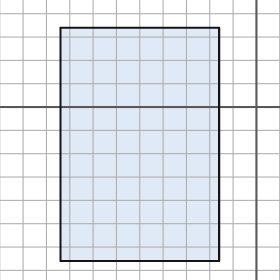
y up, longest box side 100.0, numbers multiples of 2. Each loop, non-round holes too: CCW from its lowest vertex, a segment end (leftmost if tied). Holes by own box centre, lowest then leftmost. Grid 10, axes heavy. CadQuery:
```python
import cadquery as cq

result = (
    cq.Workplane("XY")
    .moveTo(-84.0, -66.0)
    .lineTo(-16.0, -66.0)
    .lineTo(-16.0, 34.0)
    .lineTo(-84.0, 34.0)
    .close()
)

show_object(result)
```